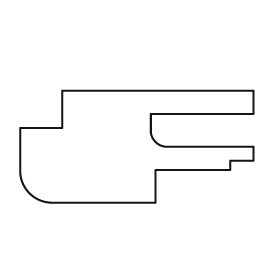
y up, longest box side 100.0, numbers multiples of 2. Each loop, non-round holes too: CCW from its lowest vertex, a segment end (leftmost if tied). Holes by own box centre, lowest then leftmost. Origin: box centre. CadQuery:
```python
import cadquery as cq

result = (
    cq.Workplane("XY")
    .moveTo(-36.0, -24.0)
    .lineTo(8.0, -24.0)
    .lineTo(8.0, -10.0)
    .lineTo(40.0, -10.0)
    .lineTo(40.0, -6.0)
    .lineTo(50.0, -6.0)
    .lineTo(50.0, 0.0)
    .lineTo(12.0, 0.0)
    .threePointArc((8.0, 2.0), (6.0, 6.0))
    .lineTo(6.0, 14.0)
    .lineTo(50.0, 14.0)
    .lineTo(50.0, 24.0)
    .lineTo(-32.0, 24.0)
    .lineTo(-32.0, 8.0)
    .lineTo(-50.0, 8.0)
    .lineTo(-50.0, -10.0)
    .threePointArc((-46.0, -20.0), (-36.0, -24.0))
    .close()
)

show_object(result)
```